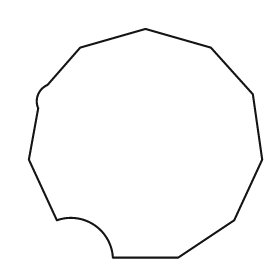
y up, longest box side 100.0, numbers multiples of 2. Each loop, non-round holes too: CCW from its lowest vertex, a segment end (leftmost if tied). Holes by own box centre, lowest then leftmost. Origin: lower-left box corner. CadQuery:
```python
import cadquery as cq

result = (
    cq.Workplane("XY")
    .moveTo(36.0, 0.0)
    .lineTo(64.0, 0.0)
    .lineTo(88.0, 16.0)
    .lineTo(100.0, 42.0)
    .lineTo(96.0, 70.0)
    .lineTo(78.0, 90.0)
    .lineTo(50.0, 98.0)
    .lineTo(22.0, 90.0)
    .lineTo(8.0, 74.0)
    .threePointArc((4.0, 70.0), (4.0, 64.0))
    .lineTo(0.0, 42.0)
    .lineTo(12.0, 16.0)
    .threePointArc((28.0, 14.0), (36.0, 0.0))
    .close()
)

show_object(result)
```